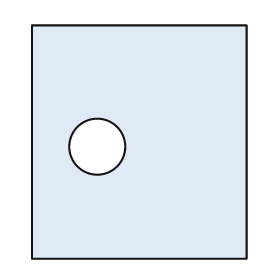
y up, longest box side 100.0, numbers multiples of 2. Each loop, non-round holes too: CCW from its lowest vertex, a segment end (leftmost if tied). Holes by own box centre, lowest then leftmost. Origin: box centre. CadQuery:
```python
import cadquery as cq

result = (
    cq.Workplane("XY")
    .moveTo(-46.0, -50.0)
    .lineTo(46.0, -50.0)
    .lineTo(46.0, 50.0)
    .lineTo(-46.0, 50.0)
    .close()
    .moveTo(-18.0, -2.0)
    .circle(12.0)
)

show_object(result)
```